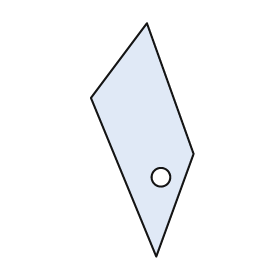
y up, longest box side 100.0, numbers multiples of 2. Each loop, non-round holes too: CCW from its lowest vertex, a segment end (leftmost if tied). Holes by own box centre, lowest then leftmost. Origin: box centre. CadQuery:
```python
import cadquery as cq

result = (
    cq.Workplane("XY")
    .moveTo(6.0, -50.0)
    .lineTo(22.0, -6.0)
    .lineTo(2.0, 50.0)
    .lineTo(-22.0, 18.0)
    .close()
    .moveTo(8.0, -16.0)
    .circle(4.0)
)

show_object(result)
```